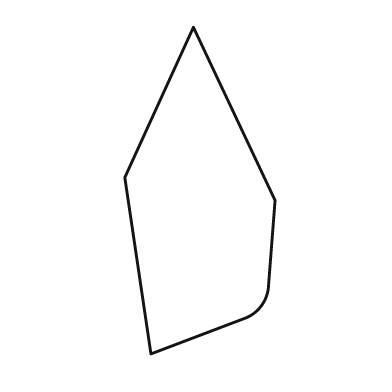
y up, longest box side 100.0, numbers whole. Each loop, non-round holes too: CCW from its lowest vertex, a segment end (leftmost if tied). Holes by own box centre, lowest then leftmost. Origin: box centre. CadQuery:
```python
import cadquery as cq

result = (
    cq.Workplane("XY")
    .moveTo(-15.0, -50.0)
    .lineTo(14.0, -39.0)
    .threePointArc((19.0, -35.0), (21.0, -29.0))
    .lineTo(23.0, -3.0)
    .lineTo(-2.0, 50.0)
    .lineTo(-23.0, 4.0)
    .close()
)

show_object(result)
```